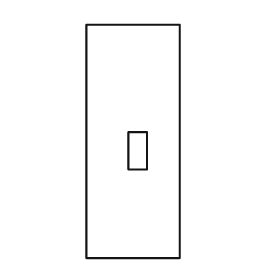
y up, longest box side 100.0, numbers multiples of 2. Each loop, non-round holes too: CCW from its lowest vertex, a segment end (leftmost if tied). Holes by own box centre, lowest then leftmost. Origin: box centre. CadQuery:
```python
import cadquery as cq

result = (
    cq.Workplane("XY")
    .moveTo(-20.0, -50.0)
    .lineTo(20.0, -50.0)
    .lineTo(20.0, 50.0)
    .lineTo(-20.0, 50.0)
    .close()
    .moveTo(-2.0, -12.0)
    .lineTo(6.0, -12.0)
    .lineTo(6.0, 4.0)
    .lineTo(-2.0, 4.0)
    .close()
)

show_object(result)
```